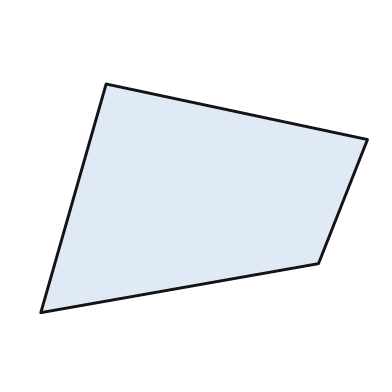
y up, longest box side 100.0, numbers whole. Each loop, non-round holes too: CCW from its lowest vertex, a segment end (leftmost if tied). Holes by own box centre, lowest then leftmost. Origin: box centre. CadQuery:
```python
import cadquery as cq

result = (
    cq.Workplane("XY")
    .moveTo(-50.0, -35.0)
    .lineTo(35.0, -20.0)
    .lineTo(50.0, 18.0)
    .lineTo(-30.0, 35.0)
    .close()
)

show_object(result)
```